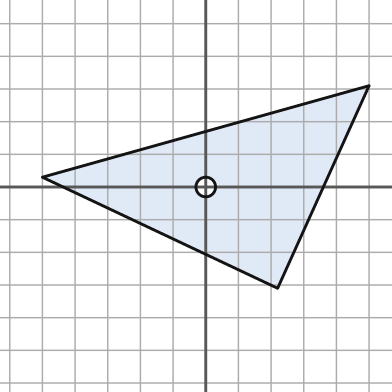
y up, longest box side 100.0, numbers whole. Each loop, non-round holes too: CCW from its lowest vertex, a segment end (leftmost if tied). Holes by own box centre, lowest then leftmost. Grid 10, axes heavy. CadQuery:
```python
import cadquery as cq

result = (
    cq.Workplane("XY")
    .moveTo(22.0, -31.0)
    .lineTo(50.0, 31.0)
    .lineTo(-50.0, 3.0)
    .close()
    .moveTo(0.0, 0.0)
    .circle(3.0)
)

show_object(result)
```